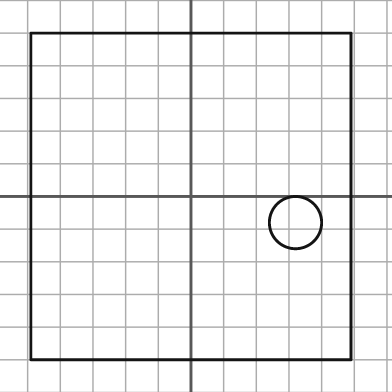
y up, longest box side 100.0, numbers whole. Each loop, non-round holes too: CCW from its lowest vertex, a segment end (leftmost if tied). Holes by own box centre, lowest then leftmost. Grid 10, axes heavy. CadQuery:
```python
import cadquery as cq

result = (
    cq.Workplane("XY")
    .moveTo(-49.0, -50.0)
    .lineTo(49.0, -50.0)
    .lineTo(49.0, 50.0)
    .lineTo(-49.0, 50.0)
    .close()
    .moveTo(32.0, -8.0)
    .circle(8.0)
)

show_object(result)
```